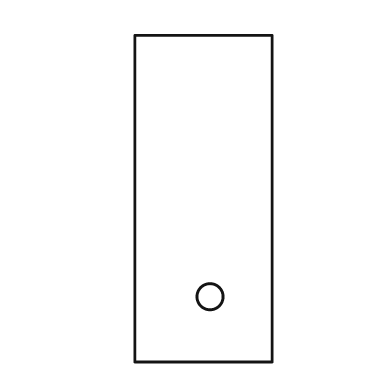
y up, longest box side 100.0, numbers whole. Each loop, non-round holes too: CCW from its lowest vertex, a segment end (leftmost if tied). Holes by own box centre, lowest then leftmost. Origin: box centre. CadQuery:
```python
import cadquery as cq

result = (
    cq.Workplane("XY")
    .moveTo(-21.0, -50.0)
    .lineTo(21.0, -50.0)
    .lineTo(21.0, 50.0)
    .lineTo(-21.0, 50.0)
    .close()
    .moveTo(2.0, -30.0)
    .circle(4.0)
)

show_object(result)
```